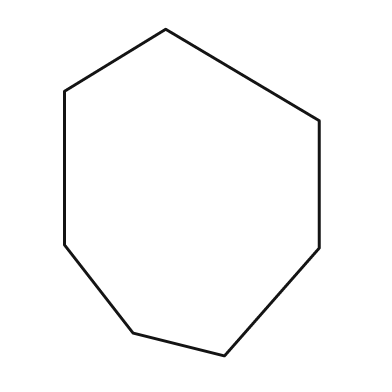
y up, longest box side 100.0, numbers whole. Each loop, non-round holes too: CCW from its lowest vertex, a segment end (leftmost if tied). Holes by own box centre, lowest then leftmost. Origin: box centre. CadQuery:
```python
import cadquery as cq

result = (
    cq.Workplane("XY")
    .moveTo(10.0, -50.0)
    .lineTo(39.0, -17.0)
    .lineTo(39.0, 22.0)
    .lineTo(-8.0, 50.0)
    .lineTo(-39.0, 31.0)
    .lineTo(-39.0, -16.0)
    .lineTo(-18.0, -43.0)
    .close()
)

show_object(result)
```